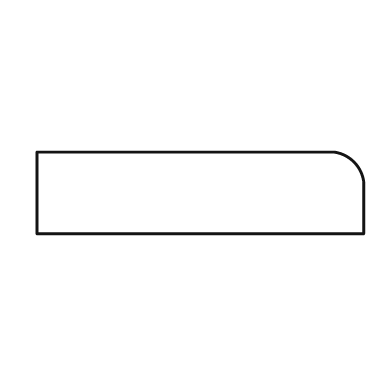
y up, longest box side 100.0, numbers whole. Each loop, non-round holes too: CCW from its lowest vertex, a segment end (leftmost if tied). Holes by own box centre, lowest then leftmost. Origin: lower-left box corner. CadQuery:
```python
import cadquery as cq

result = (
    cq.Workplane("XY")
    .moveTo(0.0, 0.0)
    .lineTo(100.0, 0.0)
    .lineTo(100.0, 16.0)
    .threePointArc((97.0, 22.0), (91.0, 25.0))
    .lineTo(0.0, 25.0)
    .close()
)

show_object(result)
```